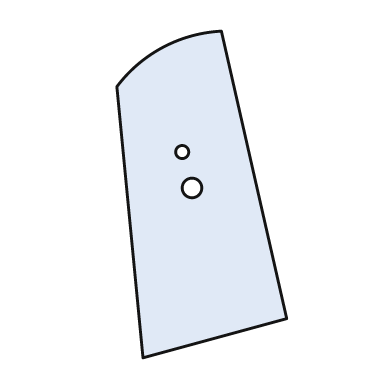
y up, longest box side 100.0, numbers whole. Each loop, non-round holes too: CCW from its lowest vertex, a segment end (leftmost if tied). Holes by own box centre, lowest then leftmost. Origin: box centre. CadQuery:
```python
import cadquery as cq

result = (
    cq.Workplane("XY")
    .moveTo(-18.0, -50.0)
    .lineTo(26.0, -38.0)
    .lineTo(6.0, 50.0)
    .threePointArc((-12.0, 45.0), (-26.0, 33.0))
    .close()
    .moveTo(-3.0, 2.0)
    .circle(3.0)
    .moveTo(-6.0, 13.0)
    .circle(2.0)
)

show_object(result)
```